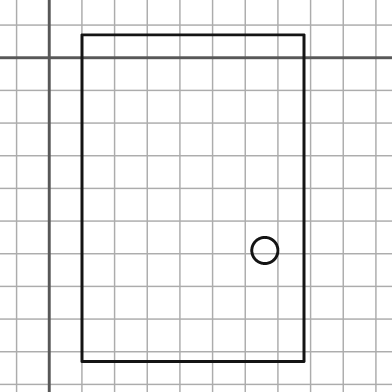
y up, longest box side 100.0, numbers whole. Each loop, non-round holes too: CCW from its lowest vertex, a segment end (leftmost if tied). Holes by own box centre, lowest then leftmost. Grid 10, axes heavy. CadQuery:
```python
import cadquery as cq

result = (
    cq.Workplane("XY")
    .moveTo(10.0, -93.0)
    .lineTo(78.0, -93.0)
    .lineTo(78.0, 7.0)
    .lineTo(10.0, 7.0)
    .close()
    .moveTo(66.0, -59.0)
    .circle(4.0)
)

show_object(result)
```